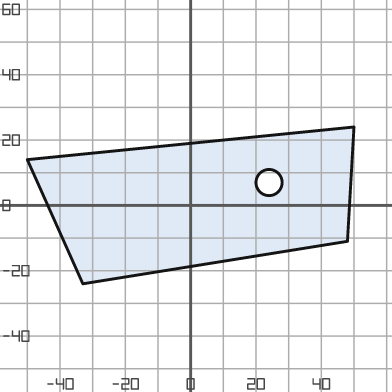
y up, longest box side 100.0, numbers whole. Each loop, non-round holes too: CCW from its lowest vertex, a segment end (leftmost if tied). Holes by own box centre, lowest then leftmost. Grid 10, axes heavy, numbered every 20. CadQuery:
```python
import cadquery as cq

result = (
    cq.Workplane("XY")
    .moveTo(-33.0, -24.0)
    .lineTo(48.0, -11.0)
    .lineTo(50.0, 24.0)
    .lineTo(-50.0, 14.0)
    .close()
    .moveTo(24.0, 7.0)
    .circle(4.0)
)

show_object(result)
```